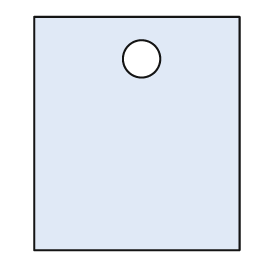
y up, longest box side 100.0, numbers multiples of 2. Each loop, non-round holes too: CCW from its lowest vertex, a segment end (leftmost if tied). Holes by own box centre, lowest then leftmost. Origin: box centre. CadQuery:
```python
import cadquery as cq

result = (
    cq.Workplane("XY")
    .moveTo(-44.0, -50.0)
    .lineTo(44.0, -50.0)
    .lineTo(44.0, 50.0)
    .lineTo(-44.0, 50.0)
    .close()
    .moveTo(2.0, 32.0)
    .circle(8.0)
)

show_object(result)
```